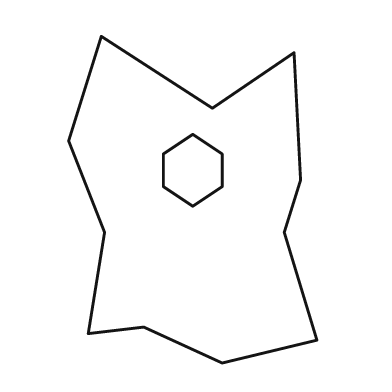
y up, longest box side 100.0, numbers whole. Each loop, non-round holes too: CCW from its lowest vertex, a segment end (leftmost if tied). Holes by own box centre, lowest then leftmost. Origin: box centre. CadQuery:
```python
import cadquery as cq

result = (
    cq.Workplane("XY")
    .moveTo(9.0, -50.0)
    .lineTo(38.0, -43.0)
    .lineTo(28.0, -10.0)
    .lineTo(33.0, 6.0)
    .lineTo(31.0, 45.0)
    .lineTo(6.0, 28.0)
    .lineTo(-28.0, 50.0)
    .lineTo(-38.0, 18.0)
    .lineTo(-27.0, -10.0)
    .lineTo(-32.0, -41.0)
    .lineTo(-15.0, -39.0)
    .close()
    .moveTo(0.0, -2.0)
    .lineTo(9.0, 4.0)
    .lineTo(9.0, 14.0)
    .lineTo(0.0, 20.0)
    .lineTo(-9.0, 14.0)
    .lineTo(-9.0, 4.0)
    .close()
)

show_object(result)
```